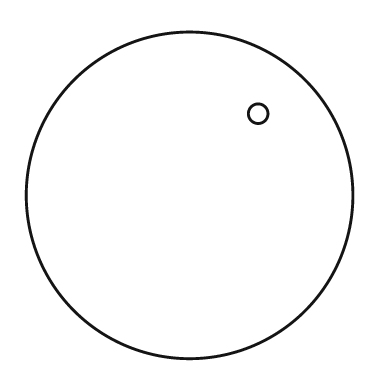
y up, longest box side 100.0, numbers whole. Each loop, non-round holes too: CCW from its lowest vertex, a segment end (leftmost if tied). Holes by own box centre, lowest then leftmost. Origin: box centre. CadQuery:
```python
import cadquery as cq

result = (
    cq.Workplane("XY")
    .moveTo(0.0, 0.0)
    .circle(50.0)
    .moveTo(21.0, 25.0)
    .circle(3.0)
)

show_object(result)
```